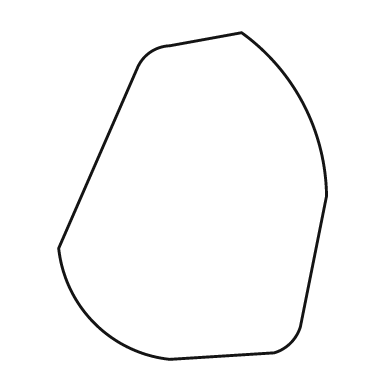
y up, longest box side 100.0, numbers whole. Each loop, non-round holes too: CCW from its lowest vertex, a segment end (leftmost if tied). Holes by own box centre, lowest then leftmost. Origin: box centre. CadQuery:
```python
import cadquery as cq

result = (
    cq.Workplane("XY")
    .moveTo(-7.0, -50.0)
    .lineTo(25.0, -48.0)
    .threePointArc((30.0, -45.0), (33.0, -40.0))
    .lineTo(41.0, 0.0)
    .threePointArc((34.0, 28.0), (15.0, 50.0))
    .lineTo(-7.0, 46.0)
    .threePointArc((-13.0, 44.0), (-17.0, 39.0))
    .lineTo(-41.0, -16.0)
    .threePointArc((-30.0, -39.0), (-7.0, -50.0))
    .close()
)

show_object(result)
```